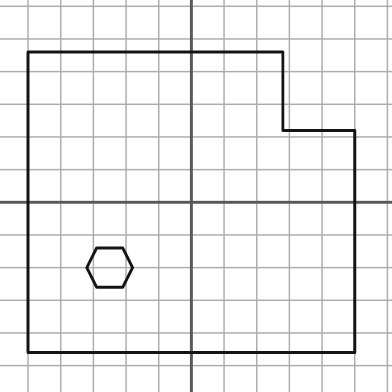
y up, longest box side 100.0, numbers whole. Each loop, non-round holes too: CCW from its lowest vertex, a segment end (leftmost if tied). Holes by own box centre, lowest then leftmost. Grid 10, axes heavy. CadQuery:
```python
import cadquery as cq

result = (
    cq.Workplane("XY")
    .moveTo(-50.0, -46.0)
    .lineTo(50.0, -46.0)
    .lineTo(50.0, 22.0)
    .lineTo(28.0, 22.0)
    .lineTo(28.0, 46.0)
    .lineTo(-50.0, 46.0)
    .close()
    .moveTo(-29.0, -26.0)
    .lineTo(-21.0, -26.0)
    .lineTo(-18.0, -20.0)
    .lineTo(-21.0, -14.0)
    .lineTo(-29.0, -14.0)
    .lineTo(-32.0, -20.0)
    .close()
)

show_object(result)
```